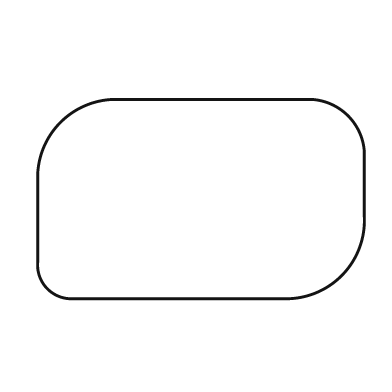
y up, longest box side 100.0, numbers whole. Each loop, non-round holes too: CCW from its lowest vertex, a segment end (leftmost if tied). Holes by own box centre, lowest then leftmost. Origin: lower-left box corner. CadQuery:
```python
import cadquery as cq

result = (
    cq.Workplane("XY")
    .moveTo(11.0, 0.0)
    .lineTo(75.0, 0.0)
    .threePointArc((93.0, 7.0), (100.0, 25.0))
    .lineTo(100.0, 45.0)
    .threePointArc((95.0, 56.0), (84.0, 61.0))
    .lineTo(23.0, 61.0)
    .threePointArc((7.0, 54.0), (0.0, 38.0))
    .lineTo(0.0, 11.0)
    .threePointArc((3.0, 3.0), (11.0, 0.0))
    .close()
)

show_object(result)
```